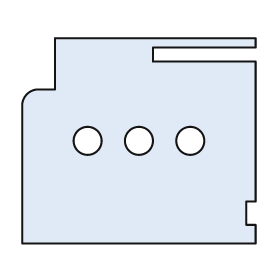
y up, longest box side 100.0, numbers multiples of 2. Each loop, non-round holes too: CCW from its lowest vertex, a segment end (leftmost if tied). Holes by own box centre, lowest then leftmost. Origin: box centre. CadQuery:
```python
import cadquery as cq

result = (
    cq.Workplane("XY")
    .moveTo(-50.0, -44.0)
    .lineTo(50.0, -44.0)
    .lineTo(50.0, -36.0)
    .lineTo(46.0, -36.0)
    .lineTo(46.0, -26.0)
    .lineTo(50.0, -26.0)
    .lineTo(50.0, 34.0)
    .lineTo(6.0, 34.0)
    .lineTo(6.0, 40.0)
    .lineTo(50.0, 40.0)
    .lineTo(50.0, 44.0)
    .lineTo(-36.0, 44.0)
    .lineTo(-36.0, 22.0)
    .lineTo(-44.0, 22.0)
    .threePointArc((-48.0, 20.0), (-50.0, 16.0))
    .close()
    .moveTo(-22.0, 0.0)
    .circle(6.0)
    .moveTo(0.0, 0.0)
    .circle(6.0)
    .moveTo(22.0, 0.0)
    .circle(6.0)
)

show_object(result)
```